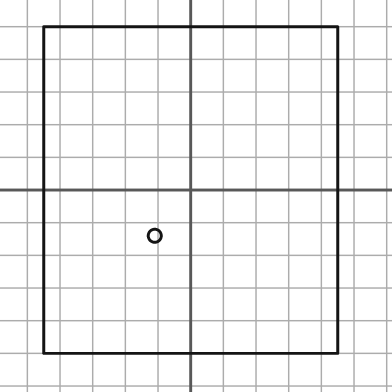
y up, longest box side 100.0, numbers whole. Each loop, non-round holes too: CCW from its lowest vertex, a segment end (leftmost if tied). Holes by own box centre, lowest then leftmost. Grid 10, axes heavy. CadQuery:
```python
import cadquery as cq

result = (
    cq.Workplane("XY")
    .moveTo(-45.0, -50.0)
    .lineTo(45.0, -50.0)
    .lineTo(45.0, 50.0)
    .lineTo(-45.0, 50.0)
    .close()
    .moveTo(-11.0, -14.0)
    .circle(2.0)
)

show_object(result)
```